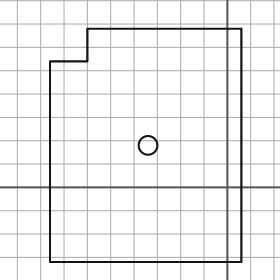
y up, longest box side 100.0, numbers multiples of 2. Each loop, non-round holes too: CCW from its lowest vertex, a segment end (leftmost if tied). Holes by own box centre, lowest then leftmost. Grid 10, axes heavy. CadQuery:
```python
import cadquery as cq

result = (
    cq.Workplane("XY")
    .moveTo(-76.0, -32.0)
    .lineTo(6.0, -32.0)
    .lineTo(6.0, 68.0)
    .lineTo(-60.0, 68.0)
    .lineTo(-60.0, 54.0)
    .lineTo(-76.0, 54.0)
    .close()
    .moveTo(-34.0, 18.0)
    .circle(4.0)
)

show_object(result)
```